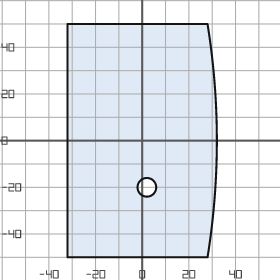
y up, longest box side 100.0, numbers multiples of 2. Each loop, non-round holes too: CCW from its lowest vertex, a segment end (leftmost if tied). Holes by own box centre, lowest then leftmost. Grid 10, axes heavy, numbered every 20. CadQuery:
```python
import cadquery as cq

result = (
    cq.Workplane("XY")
    .moveTo(-32.0, -50.0)
    .lineTo(28.0, -50.0)
    .threePointArc((32.0, 0.0), (28.0, 50.0))
    .lineTo(-32.0, 50.0)
    .close()
    .moveTo(2.0, -20.0)
    .circle(4.0)
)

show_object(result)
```